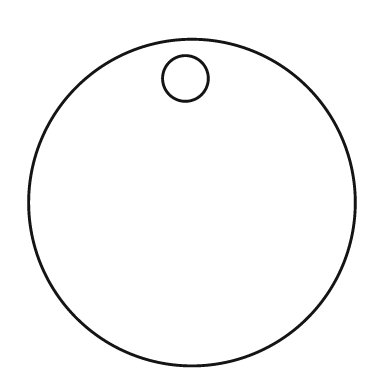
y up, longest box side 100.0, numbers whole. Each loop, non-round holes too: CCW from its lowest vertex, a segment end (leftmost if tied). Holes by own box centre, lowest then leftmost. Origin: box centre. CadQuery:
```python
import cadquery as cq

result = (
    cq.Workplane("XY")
    .moveTo(0.0, 0.0)
    .circle(50.0)
    .moveTo(-2.0, 38.0)
    .circle(7.0)
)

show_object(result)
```